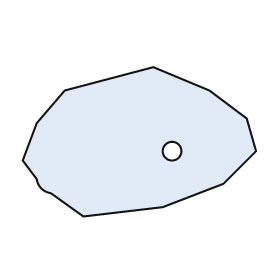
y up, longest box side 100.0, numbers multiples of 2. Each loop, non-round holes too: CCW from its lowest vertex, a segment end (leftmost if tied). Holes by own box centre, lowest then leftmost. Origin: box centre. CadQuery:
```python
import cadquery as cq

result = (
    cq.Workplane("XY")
    .moveTo(-24.0, -32.0)
    .lineTo(10.0, -28.0)
    .lineTo(36.0, -18.0)
    .lineTo(50.0, -4.0)
    .lineTo(46.0, 10.0)
    .lineTo(30.0, 22.0)
    .lineTo(6.0, 32.0)
    .lineTo(-32.0, 22.0)
    .lineTo(-44.0, 8.0)
    .lineTo(-50.0, -8.0)
    .lineTo(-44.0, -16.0)
    .threePointArc((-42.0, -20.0), (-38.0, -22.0))
    .close()
    .moveTo(14.0, -4.0)
    .circle(4.0)
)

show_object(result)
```